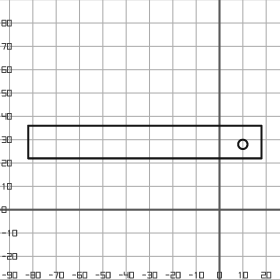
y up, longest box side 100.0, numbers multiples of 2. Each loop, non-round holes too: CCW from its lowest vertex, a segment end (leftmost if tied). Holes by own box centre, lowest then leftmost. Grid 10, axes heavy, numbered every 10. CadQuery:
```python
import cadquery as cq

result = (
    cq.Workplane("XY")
    .moveTo(-82.0, 22.0)
    .lineTo(18.0, 22.0)
    .lineTo(18.0, 36.0)
    .lineTo(-82.0, 36.0)
    .close()
    .moveTo(10.0, 28.0)
    .circle(2.0)
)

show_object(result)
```